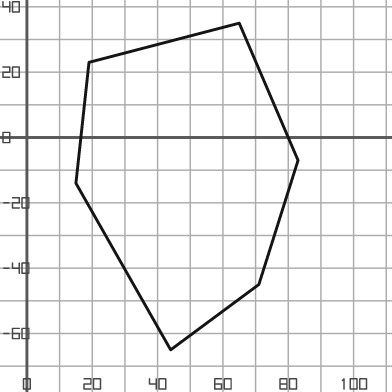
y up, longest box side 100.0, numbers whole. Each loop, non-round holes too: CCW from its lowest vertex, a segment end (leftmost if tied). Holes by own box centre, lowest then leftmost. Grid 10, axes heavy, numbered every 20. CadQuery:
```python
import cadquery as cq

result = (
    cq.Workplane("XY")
    .moveTo(44.0, -65.0)
    .lineTo(71.0, -45.0)
    .lineTo(83.0, -7.0)
    .lineTo(65.0, 35.0)
    .lineTo(19.0, 23.0)
    .lineTo(15.0, -14.0)
    .close()
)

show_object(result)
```